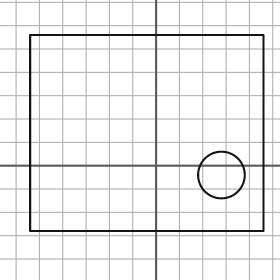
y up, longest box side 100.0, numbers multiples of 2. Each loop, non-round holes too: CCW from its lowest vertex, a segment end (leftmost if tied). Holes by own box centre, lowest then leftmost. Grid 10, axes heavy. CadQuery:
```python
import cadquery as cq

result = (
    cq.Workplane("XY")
    .moveTo(-54.0, -28.0)
    .lineTo(46.0, -28.0)
    .lineTo(46.0, 56.0)
    .lineTo(-54.0, 56.0)
    .close()
    .moveTo(28.0, -4.0)
    .circle(10.0)
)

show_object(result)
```